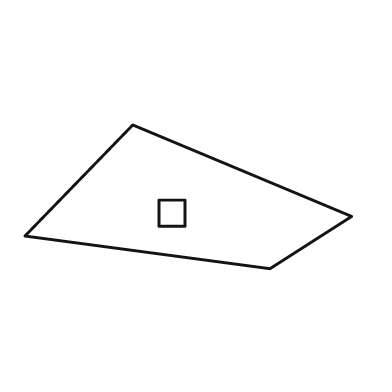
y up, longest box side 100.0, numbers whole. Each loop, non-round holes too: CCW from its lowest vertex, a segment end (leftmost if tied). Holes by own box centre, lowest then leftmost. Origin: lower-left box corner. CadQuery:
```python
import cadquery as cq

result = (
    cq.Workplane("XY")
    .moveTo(75.0, 0.0)
    .lineTo(100.0, 16.0)
    .lineTo(33.0, 44.0)
    .lineTo(0.0, 10.0)
    .close()
    .moveTo(41.0, 13.0)
    .lineTo(49.0, 13.0)
    .lineTo(49.0, 21.0)
    .lineTo(41.0, 21.0)
    .close()
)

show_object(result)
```